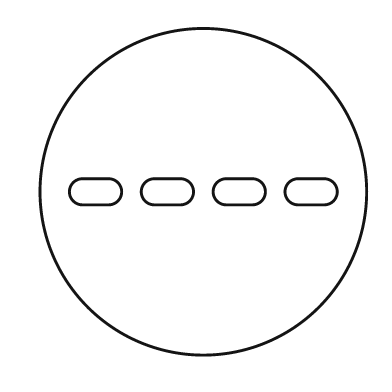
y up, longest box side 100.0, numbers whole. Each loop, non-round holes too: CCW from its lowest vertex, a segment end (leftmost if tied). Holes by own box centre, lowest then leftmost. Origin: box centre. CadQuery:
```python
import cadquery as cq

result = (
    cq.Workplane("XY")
    .moveTo(0.0, 0.0)
    .circle(50.0)
    .moveTo(-37.0, -4.0)
    .lineTo(-29.0, -4.0)
    .threePointArc((-25.0, 0.0), (-29.0, 4.0))
    .lineTo(-37.0, 4.0)
    .threePointArc((-41.0, 0.0), (-37.0, -4.0))
    .close()
    .moveTo(-15.0, -4.0)
    .lineTo(-7.0, -4.0)
    .threePointArc((-3.0, 0.0), (-7.0, 4.0))
    .lineTo(-15.0, 4.0)
    .threePointArc((-19.0, 0.0), (-15.0, -4.0))
    .close()
    .moveTo(7.0, -4.0)
    .lineTo(15.0, -4.0)
    .threePointArc((19.0, 0.0), (15.0, 4.0))
    .lineTo(7.0, 4.0)
    .threePointArc((3.0, 0.0), (7.0, -4.0))
    .close()
    .moveTo(29.0, -4.0)
    .lineTo(37.0, -4.0)
    .threePointArc((41.0, 0.0), (37.0, 4.0))
    .lineTo(29.0, 4.0)
    .threePointArc((25.0, 0.0), (29.0, -4.0))
    .close()
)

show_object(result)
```